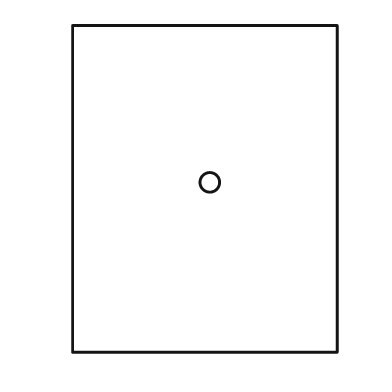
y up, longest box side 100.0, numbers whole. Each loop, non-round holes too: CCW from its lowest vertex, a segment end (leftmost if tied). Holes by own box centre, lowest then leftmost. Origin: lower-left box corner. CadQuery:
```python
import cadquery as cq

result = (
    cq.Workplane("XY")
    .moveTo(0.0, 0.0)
    .lineTo(81.0, 0.0)
    .lineTo(81.0, 100.0)
    .lineTo(0.0, 100.0)
    .close()
    .moveTo(42.0, 52.0)
    .circle(3.0)
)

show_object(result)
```